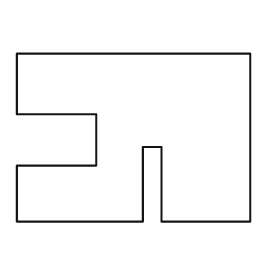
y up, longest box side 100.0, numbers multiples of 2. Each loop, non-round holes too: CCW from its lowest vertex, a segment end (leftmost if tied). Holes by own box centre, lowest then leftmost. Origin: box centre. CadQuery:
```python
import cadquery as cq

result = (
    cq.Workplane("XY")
    .moveTo(-50.0, -36.0)
    .lineTo(4.0, -36.0)
    .lineTo(4.0, -4.0)
    .lineTo(12.0, -4.0)
    .lineTo(12.0, -36.0)
    .lineTo(50.0, -36.0)
    .lineTo(50.0, 36.0)
    .lineTo(-50.0, 36.0)
    .lineTo(-50.0, 10.0)
    .lineTo(-16.0, 10.0)
    .lineTo(-16.0, -12.0)
    .lineTo(-50.0, -12.0)
    .close()
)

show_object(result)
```